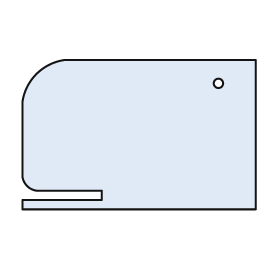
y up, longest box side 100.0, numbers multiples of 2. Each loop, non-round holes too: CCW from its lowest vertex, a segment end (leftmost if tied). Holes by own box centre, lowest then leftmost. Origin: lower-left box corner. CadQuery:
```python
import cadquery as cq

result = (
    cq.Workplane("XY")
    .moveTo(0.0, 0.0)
    .lineTo(100.0, 0.0)
    .lineTo(100.0, 64.0)
    .lineTo(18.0, 64.0)
    .threePointArc((6.0, 58.0), (0.0, 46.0))
    .lineTo(0.0, 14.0)
    .threePointArc((2.0, 10.0), (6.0, 8.0))
    .lineTo(34.0, 8.0)
    .lineTo(34.0, 4.0)
    .lineTo(0.0, 4.0)
    .close()
    .moveTo(84.0, 54.0)
    .circle(2.0)
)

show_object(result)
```